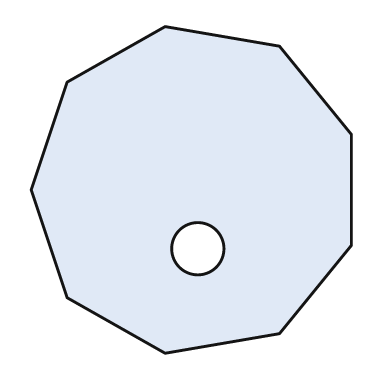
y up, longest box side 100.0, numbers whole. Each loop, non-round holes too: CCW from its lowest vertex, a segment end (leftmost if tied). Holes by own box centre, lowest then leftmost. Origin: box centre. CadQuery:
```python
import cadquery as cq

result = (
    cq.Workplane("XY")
    .moveTo(-8.0, -50.0)
    .lineTo(27.0, -44.0)
    .lineTo(49.0, -17.0)
    .lineTo(49.0, 17.0)
    .lineTo(27.0, 44.0)
    .lineTo(-8.0, 50.0)
    .lineTo(-38.0, 33.0)
    .lineTo(-49.0, 0.0)
    .lineTo(-38.0, -33.0)
    .close()
    .moveTo(2.0, -18.0)
    .circle(8.0)
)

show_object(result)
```